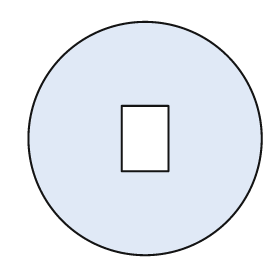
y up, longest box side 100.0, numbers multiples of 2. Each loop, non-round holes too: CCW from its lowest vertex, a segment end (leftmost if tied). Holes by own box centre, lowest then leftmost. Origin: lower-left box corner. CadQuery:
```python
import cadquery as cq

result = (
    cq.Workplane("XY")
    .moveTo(50.0, 50.0)
    .circle(50.0)
    .moveTo(40.0, 36.0)
    .lineTo(60.0, 36.0)
    .lineTo(60.0, 64.0)
    .lineTo(40.0, 64.0)
    .close()
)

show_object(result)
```